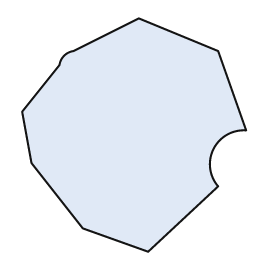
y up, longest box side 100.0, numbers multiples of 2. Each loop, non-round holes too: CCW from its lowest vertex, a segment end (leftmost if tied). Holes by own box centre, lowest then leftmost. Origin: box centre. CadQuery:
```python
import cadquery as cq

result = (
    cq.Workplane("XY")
    .moveTo(6.0, -50.0)
    .lineTo(36.0, -22.0)
    .threePointArc((34.0, -6.0), (48.0, 2.0))
    .lineTo(36.0, 36.0)
    .lineTo(2.0, 50.0)
    .lineTo(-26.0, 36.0)
    .threePointArc((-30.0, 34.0), (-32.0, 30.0))
    .lineTo(-48.0, 10.0)
    .lineTo(-44.0, -12.0)
    .lineTo(-22.0, -40.0)
    .close()
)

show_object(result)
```